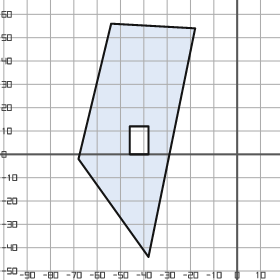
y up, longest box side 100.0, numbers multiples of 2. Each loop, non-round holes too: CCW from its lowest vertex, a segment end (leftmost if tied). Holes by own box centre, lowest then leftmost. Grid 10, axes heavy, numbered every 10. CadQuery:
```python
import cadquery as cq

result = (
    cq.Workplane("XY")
    .moveTo(-38.0, -44.0)
    .lineTo(-18.0, 54.0)
    .lineTo(-54.0, 56.0)
    .lineTo(-68.0, -2.0)
    .close()
    .moveTo(-46.0, 0.0)
    .lineTo(-38.0, 0.0)
    .lineTo(-38.0, 12.0)
    .lineTo(-46.0, 12.0)
    .close()
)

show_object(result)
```